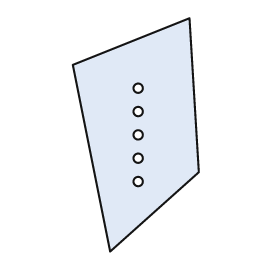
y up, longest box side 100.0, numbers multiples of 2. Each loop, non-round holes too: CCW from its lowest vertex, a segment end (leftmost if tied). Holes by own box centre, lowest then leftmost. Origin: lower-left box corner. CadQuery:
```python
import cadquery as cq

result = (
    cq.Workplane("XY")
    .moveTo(16.0, 0.0)
    .lineTo(54.0, 34.0)
    .lineTo(50.0, 100.0)
    .lineTo(0.0, 80.0)
    .close()
    .moveTo(28.0, 30.0)
    .circle(2.0)
    .moveTo(28.0, 40.0)
    .circle(2.0)
    .moveTo(28.0, 50.0)
    .circle(2.0)
    .moveTo(28.0, 60.0)
    .circle(2.0)
    .moveTo(28.0, 70.0)
    .circle(2.0)
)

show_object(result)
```